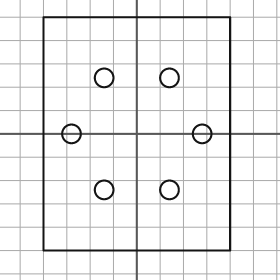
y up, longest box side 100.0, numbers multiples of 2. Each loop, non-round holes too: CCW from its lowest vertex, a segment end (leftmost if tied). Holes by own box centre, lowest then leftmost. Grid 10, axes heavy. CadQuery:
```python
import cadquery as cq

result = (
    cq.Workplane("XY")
    .moveTo(-40.0, -50.0)
    .lineTo(40.0, -50.0)
    .lineTo(40.0, 50.0)
    .lineTo(-40.0, 50.0)
    .close()
    .moveTo(-14.0, -24.0)
    .circle(4.0)
    .moveTo(14.0, -24.0)
    .circle(4.0)
    .moveTo(-28.0, 0.0)
    .circle(4.0)
    .moveTo(28.0, 0.0)
    .circle(4.0)
    .moveTo(-14.0, 24.0)
    .circle(4.0)
    .moveTo(14.0, 24.0)
    .circle(4.0)
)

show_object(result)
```